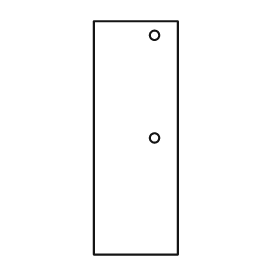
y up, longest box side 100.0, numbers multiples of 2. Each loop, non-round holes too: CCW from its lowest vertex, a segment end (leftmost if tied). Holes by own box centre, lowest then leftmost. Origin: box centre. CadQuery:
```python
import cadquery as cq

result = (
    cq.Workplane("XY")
    .moveTo(-18.0, -50.0)
    .lineTo(18.0, -50.0)
    .lineTo(18.0, 50.0)
    .lineTo(-18.0, 50.0)
    .close()
    .moveTo(8.0, 0.0)
    .circle(2.0)
    .moveTo(8.0, 44.0)
    .circle(2.0)
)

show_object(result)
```